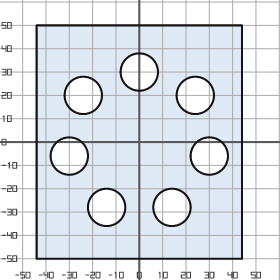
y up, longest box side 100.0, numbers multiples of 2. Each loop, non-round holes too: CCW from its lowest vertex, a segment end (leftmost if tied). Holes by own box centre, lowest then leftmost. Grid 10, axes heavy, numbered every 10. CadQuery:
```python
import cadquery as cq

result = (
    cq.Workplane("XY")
    .moveTo(-44.0, -50.0)
    .lineTo(44.0, -50.0)
    .lineTo(44.0, 50.0)
    .lineTo(-44.0, 50.0)
    .close()
    .moveTo(-14.0, -28.0)
    .circle(8.0)
    .moveTo(14.0, -28.0)
    .circle(8.0)
    .moveTo(-30.0, -6.0)
    .circle(8.0)
    .moveTo(30.0, -6.0)
    .circle(8.0)
    .moveTo(-24.0, 20.0)
    .circle(8.0)
    .moveTo(24.0, 20.0)
    .circle(8.0)
    .moveTo(0.0, 30.0)
    .circle(8.0)
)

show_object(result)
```